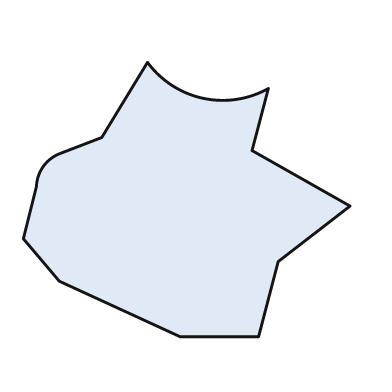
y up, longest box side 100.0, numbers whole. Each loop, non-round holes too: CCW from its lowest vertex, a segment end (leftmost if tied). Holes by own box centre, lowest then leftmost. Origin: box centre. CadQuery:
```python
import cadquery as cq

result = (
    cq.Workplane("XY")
    .moveTo(-2.0, -42.0)
    .lineTo(22.0, -42.0)
    .lineTo(28.0, -19.0)
    .lineTo(50.0, -2.0)
    .lineTo(20.0, 15.0)
    .lineTo(25.0, 34.0)
    .threePointArc((5.0, 31.0), (-12.0, 42.0))
    .lineTo(-26.0, 19.0)
    .lineTo(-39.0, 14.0)
    .threePointArc((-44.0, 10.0), (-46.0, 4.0))
    .lineTo(-50.0, -12.0)
    .lineTo(-39.0, -25.0)
    .close()
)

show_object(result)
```